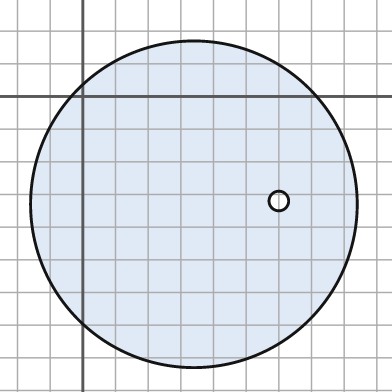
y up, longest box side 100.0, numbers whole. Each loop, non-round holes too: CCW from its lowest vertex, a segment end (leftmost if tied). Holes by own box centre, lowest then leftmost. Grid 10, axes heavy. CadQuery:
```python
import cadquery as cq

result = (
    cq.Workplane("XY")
    .moveTo(34.0, -33.0)
    .circle(50.0)
    .moveTo(60.0, -32.0)
    .circle(3.0)
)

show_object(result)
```